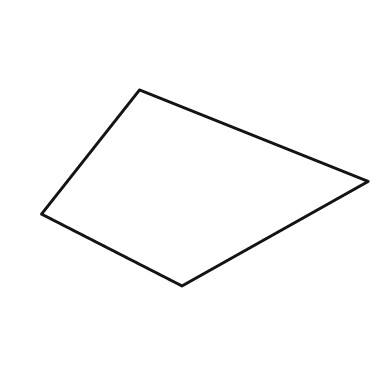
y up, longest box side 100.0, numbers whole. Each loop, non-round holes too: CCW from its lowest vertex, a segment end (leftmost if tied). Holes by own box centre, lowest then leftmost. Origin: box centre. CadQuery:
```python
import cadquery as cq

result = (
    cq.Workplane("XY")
    .moveTo(-7.0, -30.0)
    .lineTo(50.0, 2.0)
    .lineTo(-20.0, 30.0)
    .lineTo(-50.0, -8.0)
    .close()
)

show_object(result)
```